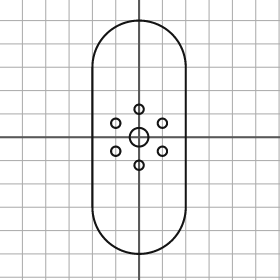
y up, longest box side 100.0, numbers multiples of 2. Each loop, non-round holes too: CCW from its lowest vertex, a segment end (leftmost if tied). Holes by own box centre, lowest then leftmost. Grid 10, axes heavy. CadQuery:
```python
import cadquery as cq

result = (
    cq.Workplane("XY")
    .moveTo(-20.0, -30.0)
    .threePointArc((0.0, -50.0), (20.0, -30.0))
    .lineTo(20.0, 30.0)
    .threePointArc((0.0, 50.0), (-20.0, 30.0))
    .close()
    .moveTo(0.0, -12.0)
    .circle(2.0)
    .moveTo(-10.0, -6.0)
    .circle(2.0)
    .moveTo(10.0, -6.0)
    .circle(2.0)
    .moveTo(0.0, 0.0)
    .circle(4.0)
    .moveTo(-10.0, 6.0)
    .circle(2.0)
    .moveTo(10.0, 6.0)
    .circle(2.0)
    .moveTo(0.0, 12.0)
    .circle(2.0)
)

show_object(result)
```